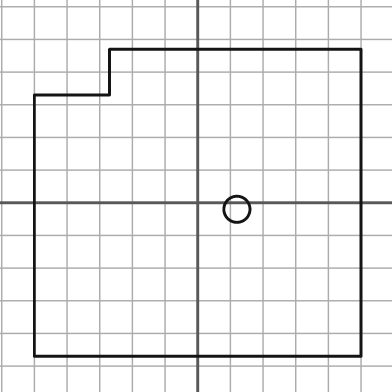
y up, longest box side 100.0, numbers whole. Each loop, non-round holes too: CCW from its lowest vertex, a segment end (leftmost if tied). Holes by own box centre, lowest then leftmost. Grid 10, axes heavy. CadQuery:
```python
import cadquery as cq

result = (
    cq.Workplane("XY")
    .moveTo(-50.0, -47.0)
    .lineTo(50.0, -47.0)
    .lineTo(50.0, 47.0)
    .lineTo(-27.0, 47.0)
    .lineTo(-27.0, 33.0)
    .lineTo(-50.0, 33.0)
    .close()
    .moveTo(12.0, -2.0)
    .circle(4.0)
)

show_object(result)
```